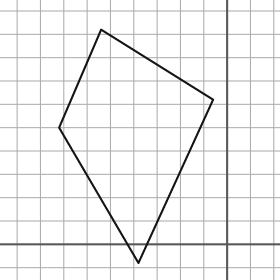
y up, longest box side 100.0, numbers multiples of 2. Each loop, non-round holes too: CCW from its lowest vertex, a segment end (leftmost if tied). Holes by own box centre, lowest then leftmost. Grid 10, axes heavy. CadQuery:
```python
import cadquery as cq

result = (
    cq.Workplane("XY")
    .moveTo(-38.0, -8.0)
    .lineTo(-6.0, 62.0)
    .lineTo(-54.0, 92.0)
    .lineTo(-72.0, 50.0)
    .close()
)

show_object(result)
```